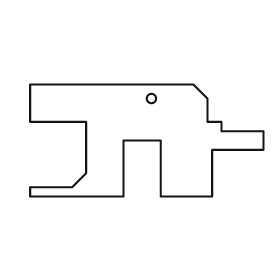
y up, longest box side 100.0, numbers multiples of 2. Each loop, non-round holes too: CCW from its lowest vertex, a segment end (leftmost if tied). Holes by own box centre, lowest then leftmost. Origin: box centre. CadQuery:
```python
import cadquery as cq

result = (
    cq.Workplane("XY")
    .moveTo(-50.0, -24.0)
    .lineTo(-10.0, -24.0)
    .lineTo(-10.0, 0.0)
    .lineTo(6.0, 0.0)
    .lineTo(6.0, -24.0)
    .lineTo(28.0, -24.0)
    .lineTo(28.0, -4.0)
    .lineTo(50.0, -4.0)
    .lineTo(50.0, 4.0)
    .lineTo(32.0, 4.0)
    .lineTo(32.0, 8.0)
    .lineTo(26.0, 8.0)
    .lineTo(26.0, 18.0)
    .lineTo(20.0, 24.0)
    .lineTo(-50.0, 24.0)
    .lineTo(-50.0, 8.0)
    .lineTo(-26.0, 8.0)
    .lineTo(-26.0, -14.0)
    .lineTo(-32.0, -20.0)
    .lineTo(-50.0, -20.0)
    .close()
    .moveTo(2.0, 18.0)
    .circle(2.0)
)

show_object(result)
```